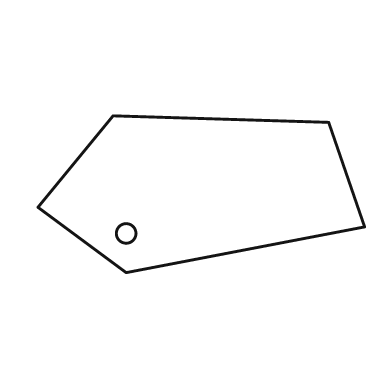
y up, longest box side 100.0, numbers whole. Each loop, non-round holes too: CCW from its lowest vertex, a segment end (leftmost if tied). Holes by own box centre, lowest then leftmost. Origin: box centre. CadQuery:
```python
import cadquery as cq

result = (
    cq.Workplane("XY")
    .moveTo(-23.0, -24.0)
    .lineTo(50.0, -10.0)
    .lineTo(39.0, 22.0)
    .lineTo(-27.0, 24.0)
    .lineTo(-50.0, -4.0)
    .close()
    .moveTo(-23.0, -12.0)
    .circle(3.0)
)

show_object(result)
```